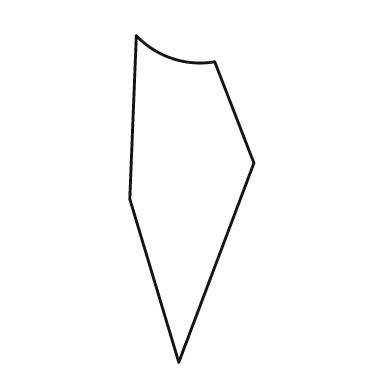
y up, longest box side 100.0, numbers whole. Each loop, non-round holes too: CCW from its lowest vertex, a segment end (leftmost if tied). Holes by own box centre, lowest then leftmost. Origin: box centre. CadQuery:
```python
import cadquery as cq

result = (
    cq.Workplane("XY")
    .moveTo(-4.0, -50.0)
    .lineTo(19.0, 11.0)
    .lineTo(7.0, 42.0)
    .threePointArc((-6.0, 43.0), (-17.0, 50.0))
    .lineTo(-19.0, 0.0)
    .close()
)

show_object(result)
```